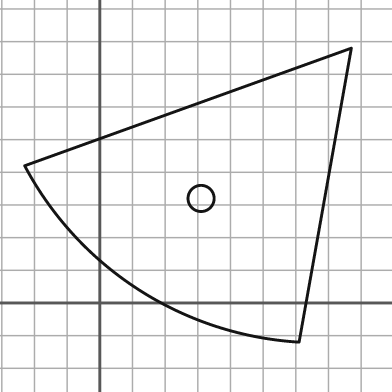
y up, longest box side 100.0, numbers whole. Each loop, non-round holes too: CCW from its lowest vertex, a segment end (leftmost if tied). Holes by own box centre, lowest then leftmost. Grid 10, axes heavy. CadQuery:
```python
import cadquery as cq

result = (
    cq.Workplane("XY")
    .moveTo(61.0, -12.0)
    .lineTo(77.0, 78.0)
    .lineTo(-23.0, 42.0)
    .threePointArc((12.0, 4.0), (61.0, -12.0))
    .close()
    .moveTo(31.0, 32.0)
    .circle(4.0)
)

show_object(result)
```